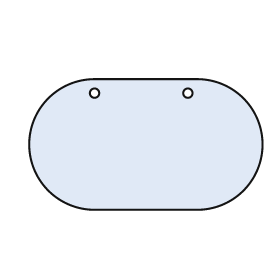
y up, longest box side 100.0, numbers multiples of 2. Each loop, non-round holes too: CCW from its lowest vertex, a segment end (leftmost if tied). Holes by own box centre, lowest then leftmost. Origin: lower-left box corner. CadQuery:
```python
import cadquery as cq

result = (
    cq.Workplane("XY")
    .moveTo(28.0, 0.0)
    .lineTo(72.0, 0.0)
    .threePointArc((100.0, 28.0), (72.0, 56.0))
    .lineTo(28.0, 56.0)
    .threePointArc((0.0, 28.0), (28.0, 0.0))
    .close()
    .moveTo(28.0, 50.0)
    .circle(2.0)
    .moveTo(68.0, 50.0)
    .circle(2.0)
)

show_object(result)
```